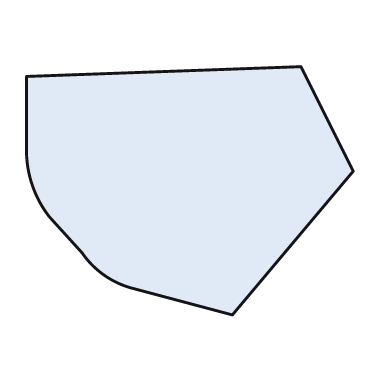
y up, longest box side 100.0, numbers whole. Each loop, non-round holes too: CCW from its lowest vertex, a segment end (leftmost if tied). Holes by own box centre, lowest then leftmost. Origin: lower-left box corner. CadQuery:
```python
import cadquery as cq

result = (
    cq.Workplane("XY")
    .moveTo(63.0, 0.0)
    .lineTo(100.0, 44.0)
    .lineTo(84.0, 76.0)
    .lineTo(0.0, 73.0)
    .lineTo(0.0, 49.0)
    .threePointArc((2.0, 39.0), (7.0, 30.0))
    .lineTo(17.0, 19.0)
    .threePointArc((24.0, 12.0), (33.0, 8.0))
    .close()
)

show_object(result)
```